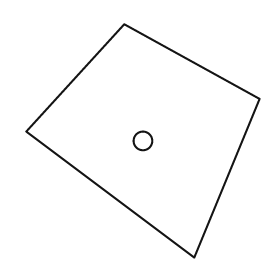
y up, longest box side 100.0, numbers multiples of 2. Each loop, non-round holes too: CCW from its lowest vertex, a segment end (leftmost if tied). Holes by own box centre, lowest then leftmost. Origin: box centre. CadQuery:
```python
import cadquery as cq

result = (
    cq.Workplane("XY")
    .moveTo(22.0, -50.0)
    .lineTo(50.0, 18.0)
    .lineTo(-8.0, 50.0)
    .lineTo(-50.0, 4.0)
    .close()
    .moveTo(0.0, 0.0)
    .circle(4.0)
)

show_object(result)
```